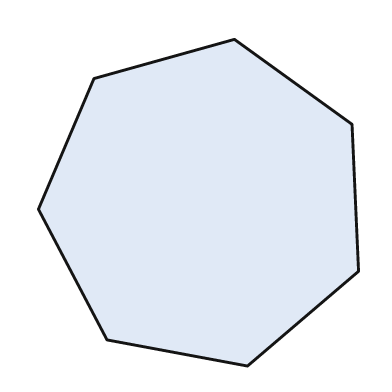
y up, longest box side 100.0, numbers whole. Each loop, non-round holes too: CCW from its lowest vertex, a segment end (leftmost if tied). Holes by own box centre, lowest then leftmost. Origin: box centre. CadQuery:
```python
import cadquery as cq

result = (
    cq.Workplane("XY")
    .moveTo(15.0, -50.0)
    .lineTo(49.0, -21.0)
    .lineTo(47.0, 24.0)
    .lineTo(11.0, 50.0)
    .lineTo(-32.0, 38.0)
    .lineTo(-49.0, -2.0)
    .lineTo(-28.0, -42.0)
    .close()
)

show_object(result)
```